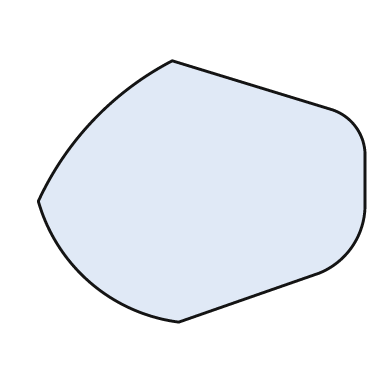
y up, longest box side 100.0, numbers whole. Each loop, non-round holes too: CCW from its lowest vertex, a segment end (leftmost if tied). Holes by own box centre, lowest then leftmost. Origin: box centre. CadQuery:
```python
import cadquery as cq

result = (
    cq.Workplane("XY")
    .moveTo(-7.0, -40.0)
    .lineTo(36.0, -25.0)
    .threePointArc((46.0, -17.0), (50.0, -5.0))
    .lineTo(50.0, 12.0)
    .threePointArc((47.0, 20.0), (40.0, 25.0))
    .lineTo(-9.0, 40.0)
    .threePointArc((-33.0, 22.0), (-50.0, -3.0))
    .threePointArc((-34.0, -28.0), (-7.0, -40.0))
    .close()
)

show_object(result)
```